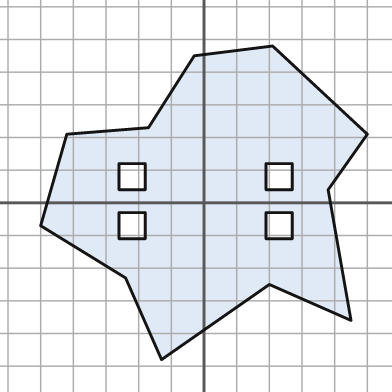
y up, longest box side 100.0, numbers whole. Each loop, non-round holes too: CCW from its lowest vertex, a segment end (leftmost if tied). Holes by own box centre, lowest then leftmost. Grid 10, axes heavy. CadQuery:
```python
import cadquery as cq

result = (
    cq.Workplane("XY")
    .moveTo(-13.0, -48.0)
    .lineTo(20.0, -25.0)
    .lineTo(45.0, -36.0)
    .lineTo(38.0, 4.0)
    .lineTo(50.0, 21.0)
    .lineTo(21.0, 48.0)
    .lineTo(-3.0, 45.0)
    .lineTo(-17.0, 23.0)
    .lineTo(-42.0, 21.0)
    .lineTo(-50.0, -7.0)
    .lineTo(-24.0, -23.0)
    .close()
    .moveTo(-26.0, -11.0)
    .lineTo(-18.0, -11.0)
    .lineTo(-18.0, -3.0)
    .lineTo(-26.0, -3.0)
    .close()
    .moveTo(19.0, -11.0)
    .lineTo(27.0, -11.0)
    .lineTo(27.0, -3.0)
    .lineTo(19.0, -3.0)
    .close()
    .moveTo(-26.0, 4.0)
    .lineTo(-18.0, 4.0)
    .lineTo(-18.0, 12.0)
    .lineTo(-26.0, 12.0)
    .close()
    .moveTo(19.0, 4.0)
    .lineTo(27.0, 4.0)
    .lineTo(27.0, 12.0)
    .lineTo(19.0, 12.0)
    .close()
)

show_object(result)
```